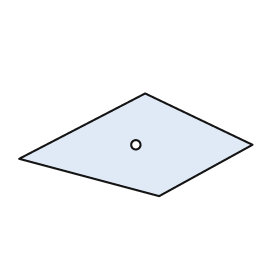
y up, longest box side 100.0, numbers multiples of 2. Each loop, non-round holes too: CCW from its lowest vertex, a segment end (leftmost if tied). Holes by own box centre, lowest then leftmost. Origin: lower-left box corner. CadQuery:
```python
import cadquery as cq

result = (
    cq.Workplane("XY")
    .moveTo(60.0, 0.0)
    .lineTo(100.0, 22.0)
    .lineTo(54.0, 44.0)
    .lineTo(0.0, 16.0)
    .close()
    .moveTo(50.0, 22.0)
    .circle(2.0)
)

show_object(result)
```